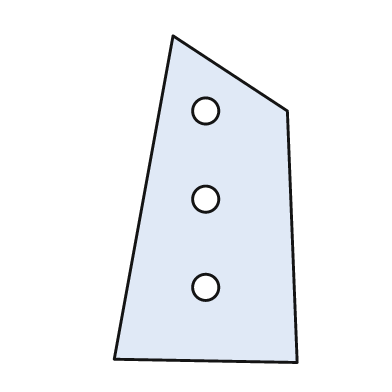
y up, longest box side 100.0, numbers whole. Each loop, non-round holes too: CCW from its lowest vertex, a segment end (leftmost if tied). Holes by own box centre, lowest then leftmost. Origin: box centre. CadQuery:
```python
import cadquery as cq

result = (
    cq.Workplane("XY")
    .moveTo(28.0, -50.0)
    .lineTo(25.0, 27.0)
    .lineTo(-10.0, 50.0)
    .lineTo(-28.0, -49.0)
    .close()
    .moveTo(0.0, -27.0)
    .circle(4.0)
    .moveTo(0.0, 0.0)
    .circle(4.0)
    .moveTo(0.0, 27.0)
    .circle(4.0)
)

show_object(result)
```